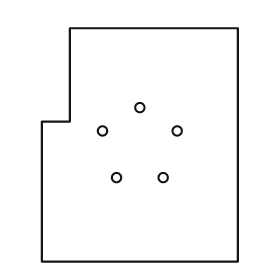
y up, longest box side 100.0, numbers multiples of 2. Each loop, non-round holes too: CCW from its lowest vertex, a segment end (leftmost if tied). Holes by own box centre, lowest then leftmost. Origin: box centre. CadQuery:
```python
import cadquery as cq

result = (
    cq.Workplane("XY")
    .moveTo(-42.0, -50.0)
    .lineTo(42.0, -50.0)
    .lineTo(42.0, 50.0)
    .lineTo(-30.0, 50.0)
    .lineTo(-30.0, 10.0)
    .lineTo(-42.0, 10.0)
    .close()
    .moveTo(-10.0, -14.0)
    .circle(2.0)
    .moveTo(10.0, -14.0)
    .circle(2.0)
    .moveTo(-16.0, 6.0)
    .circle(2.0)
    .moveTo(16.0, 6.0)
    .circle(2.0)
    .moveTo(0.0, 16.0)
    .circle(2.0)
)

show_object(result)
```